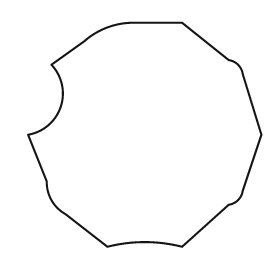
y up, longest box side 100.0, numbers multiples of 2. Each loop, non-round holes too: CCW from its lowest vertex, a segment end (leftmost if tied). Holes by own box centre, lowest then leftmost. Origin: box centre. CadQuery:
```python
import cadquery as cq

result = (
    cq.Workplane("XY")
    .moveTo(-16.0, -48.0)
    .threePointArc((0.0, -46.0), (16.0, -48.0))
    .lineTo(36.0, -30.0)
    .threePointArc((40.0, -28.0), (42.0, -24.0))
    .lineTo(50.0, 0.0)
    .lineTo(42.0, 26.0)
    .threePointArc((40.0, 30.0), (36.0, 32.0))
    .lineTo(16.0, 48.0)
    .lineTo(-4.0, 48.0)
    .threePointArc((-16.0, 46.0), (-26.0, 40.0))
    .lineTo(-40.0, 30.0)
    .threePointArc((-36.0, 12.0), (-50.0, 0.0))
    .lineTo(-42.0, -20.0)
    .threePointArc((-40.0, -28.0), (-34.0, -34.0))
    .close()
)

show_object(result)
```